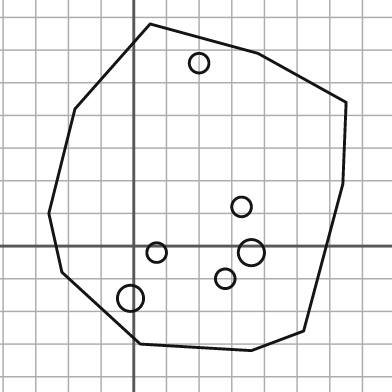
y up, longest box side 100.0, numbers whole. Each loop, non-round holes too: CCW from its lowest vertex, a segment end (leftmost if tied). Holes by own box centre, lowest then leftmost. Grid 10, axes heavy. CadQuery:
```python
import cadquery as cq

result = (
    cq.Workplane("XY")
    .moveTo(36.0, -32.0)
    .lineTo(52.0, -26.0)
    .lineTo(64.0, 19.0)
    .lineTo(65.0, 44.0)
    .lineTo(38.0, 59.0)
    .lineTo(5.0, 68.0)
    .lineTo(-18.0, 42.0)
    .lineTo(-26.0, 10.0)
    .lineTo(-22.0, -8.0)
    .lineTo(2.0, -30.0)
    .close()
    .moveTo(-1.0, -16.0)
    .circle(4.0)
    .moveTo(28.0, -10.0)
    .circle(3.0)
    .moveTo(7.0, -2.0)
    .circle(3.0)
    .moveTo(36.0, -2.0)
    .circle(4.0)
    .moveTo(33.0, 12.0)
    .circle(3.0)
    .moveTo(20.0, 56.0)
    .circle(3.0)
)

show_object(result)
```